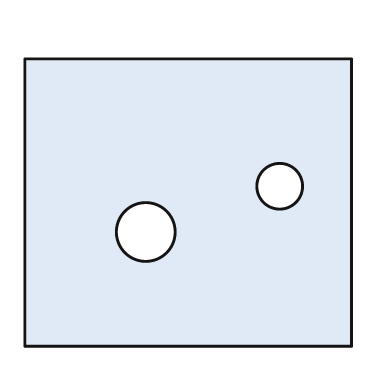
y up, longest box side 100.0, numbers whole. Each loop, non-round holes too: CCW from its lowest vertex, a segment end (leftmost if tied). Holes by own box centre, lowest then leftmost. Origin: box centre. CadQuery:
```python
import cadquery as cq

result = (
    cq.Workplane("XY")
    .moveTo(-50.0, -44.0)
    .lineTo(50.0, -44.0)
    .lineTo(50.0, 44.0)
    .lineTo(-50.0, 44.0)
    .close()
    .moveTo(-13.0, -9.0)
    .circle(9.0)
    .moveTo(28.0, 5.0)
    .circle(7.0)
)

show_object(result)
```